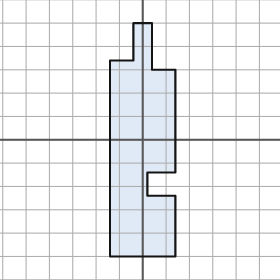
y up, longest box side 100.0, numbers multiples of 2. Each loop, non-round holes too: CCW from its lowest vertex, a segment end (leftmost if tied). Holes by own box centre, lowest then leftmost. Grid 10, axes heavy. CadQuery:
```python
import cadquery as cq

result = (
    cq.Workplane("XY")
    .moveTo(-14.0, -50.0)
    .lineTo(14.0, -50.0)
    .lineTo(14.0, -24.0)
    .lineTo(2.0, -24.0)
    .lineTo(2.0, -14.0)
    .lineTo(14.0, -14.0)
    .lineTo(14.0, 30.0)
    .lineTo(4.0, 30.0)
    .lineTo(4.0, 50.0)
    .lineTo(-4.0, 50.0)
    .lineTo(-4.0, 34.0)
    .lineTo(-14.0, 34.0)
    .close()
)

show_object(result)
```